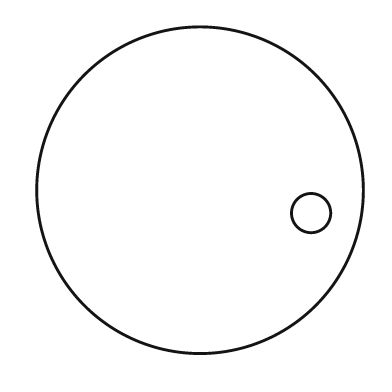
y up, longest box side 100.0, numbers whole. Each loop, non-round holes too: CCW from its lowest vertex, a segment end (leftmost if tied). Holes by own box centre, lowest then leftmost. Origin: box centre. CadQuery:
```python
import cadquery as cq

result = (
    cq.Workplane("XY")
    .moveTo(0.0, 0.0)
    .circle(50.0)
    .moveTo(34.0, -7.0)
    .circle(6.0)
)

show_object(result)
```